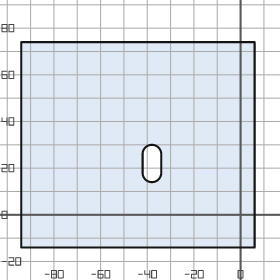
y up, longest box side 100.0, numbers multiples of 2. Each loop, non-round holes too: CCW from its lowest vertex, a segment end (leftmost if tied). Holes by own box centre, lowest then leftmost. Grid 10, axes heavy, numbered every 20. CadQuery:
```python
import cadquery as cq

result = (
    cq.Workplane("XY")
    .moveTo(-94.0, -14.0)
    .lineTo(6.0, -14.0)
    .lineTo(6.0, 74.0)
    .lineTo(-94.0, 74.0)
    .close()
    .moveTo(-42.0, 18.0)
    .threePointArc((-38.0, 14.0), (-34.0, 18.0))
    .lineTo(-34.0, 26.0)
    .threePointArc((-38.0, 30.0), (-42.0, 26.0))
    .close()
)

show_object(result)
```